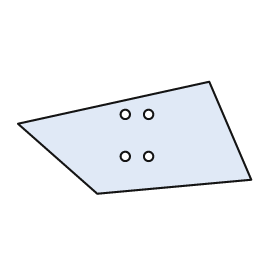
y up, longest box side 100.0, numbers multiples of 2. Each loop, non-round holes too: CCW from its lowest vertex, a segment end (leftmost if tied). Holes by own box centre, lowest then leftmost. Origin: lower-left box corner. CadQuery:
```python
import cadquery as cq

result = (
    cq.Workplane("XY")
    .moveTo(34.0, 0.0)
    .lineTo(100.0, 6.0)
    .lineTo(82.0, 48.0)
    .lineTo(0.0, 30.0)
    .close()
    .moveTo(46.0, 16.0)
    .circle(2.0)
    .moveTo(56.0, 16.0)
    .circle(2.0)
    .moveTo(46.0, 34.0)
    .circle(2.0)
    .moveTo(56.0, 34.0)
    .circle(2.0)
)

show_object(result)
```